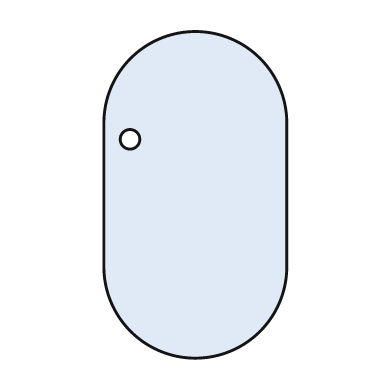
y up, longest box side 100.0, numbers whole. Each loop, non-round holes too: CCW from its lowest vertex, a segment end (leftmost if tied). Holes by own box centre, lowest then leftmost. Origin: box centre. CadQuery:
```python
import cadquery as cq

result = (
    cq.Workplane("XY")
    .moveTo(-28.0, -22.0)
    .threePointArc((0.0, -50.0), (28.0, -22.0))
    .lineTo(28.0, 22.0)
    .threePointArc((0.0, 50.0), (-28.0, 22.0))
    .close()
    .moveTo(-20.0, 17.0)
    .circle(3.0)
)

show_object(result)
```